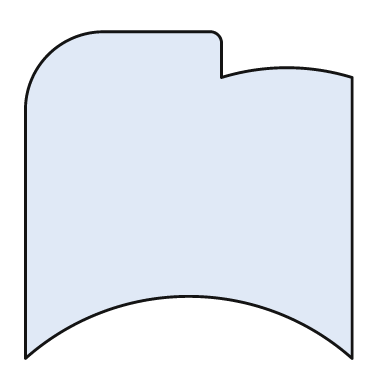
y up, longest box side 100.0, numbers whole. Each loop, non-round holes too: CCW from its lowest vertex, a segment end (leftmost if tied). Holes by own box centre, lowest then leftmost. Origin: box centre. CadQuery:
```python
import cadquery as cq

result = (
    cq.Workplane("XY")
    .moveTo(-50.0, -50.0)
    .threePointArc((0.0, -31.0), (50.0, -50.0))
    .lineTo(50.0, 36.0)
    .threePointArc((30.0, 39.0), (10.0, 36.0))
    .lineTo(10.0, 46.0)
    .threePointArc((9.0, 49.0), (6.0, 50.0))
    .lineTo(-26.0, 50.0)
    .threePointArc((-43.0, 43.0), (-50.0, 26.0))
    .close()
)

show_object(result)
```